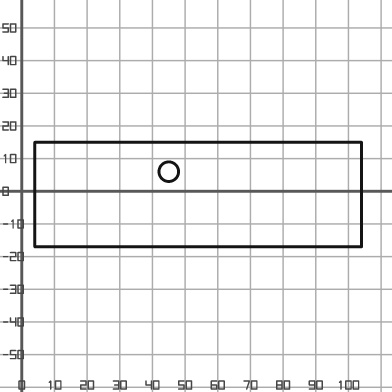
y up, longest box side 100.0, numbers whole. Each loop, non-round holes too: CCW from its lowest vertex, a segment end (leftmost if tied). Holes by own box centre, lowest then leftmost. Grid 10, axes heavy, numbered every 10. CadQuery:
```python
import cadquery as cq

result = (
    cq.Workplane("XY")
    .moveTo(4.0, -17.0)
    .lineTo(104.0, -17.0)
    .lineTo(104.0, 15.0)
    .lineTo(4.0, 15.0)
    .close()
    .moveTo(45.0, 6.0)
    .circle(3.0)
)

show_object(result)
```